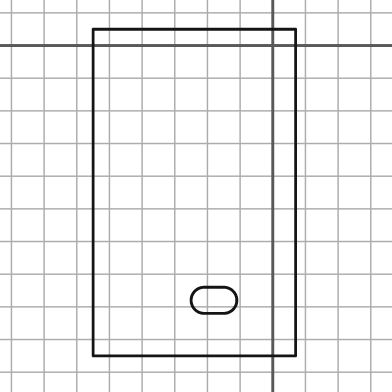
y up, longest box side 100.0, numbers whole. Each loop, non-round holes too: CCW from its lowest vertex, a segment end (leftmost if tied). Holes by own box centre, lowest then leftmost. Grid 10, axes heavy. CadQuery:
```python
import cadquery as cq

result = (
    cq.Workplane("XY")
    .moveTo(-55.0, -95.0)
    .lineTo(7.0, -95.0)
    .lineTo(7.0, 5.0)
    .lineTo(-55.0, 5.0)
    .close()
    .moveTo(-21.0, -82.0)
    .lineTo(-15.0, -82.0)
    .threePointArc((-11.0, -78.0), (-15.0, -74.0))
    .lineTo(-21.0, -74.0)
    .threePointArc((-25.0, -78.0), (-21.0, -82.0))
    .close()
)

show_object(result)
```